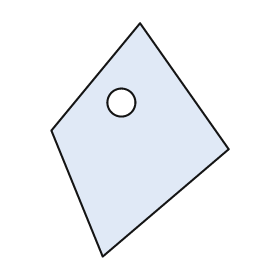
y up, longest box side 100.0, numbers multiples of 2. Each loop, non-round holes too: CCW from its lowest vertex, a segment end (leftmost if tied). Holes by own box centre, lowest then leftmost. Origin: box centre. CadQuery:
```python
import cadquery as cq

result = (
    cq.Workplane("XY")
    .moveTo(-16.0, -50.0)
    .lineTo(38.0, -4.0)
    .lineTo(0.0, 50.0)
    .lineTo(-38.0, 4.0)
    .close()
    .moveTo(-8.0, 16.0)
    .circle(6.0)
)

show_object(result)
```